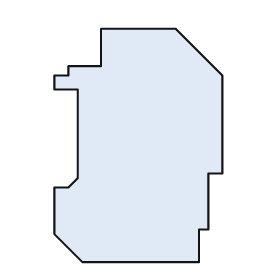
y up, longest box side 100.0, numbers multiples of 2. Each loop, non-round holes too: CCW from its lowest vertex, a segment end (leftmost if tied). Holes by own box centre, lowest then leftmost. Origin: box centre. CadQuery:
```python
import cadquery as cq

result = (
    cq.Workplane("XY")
    .moveTo(-24.0, -50.0)
    .lineTo(26.0, -50.0)
    .lineTo(26.0, -36.0)
    .lineTo(30.0, -36.0)
    .lineTo(30.0, -12.0)
    .lineTo(36.0, -12.0)
    .lineTo(36.0, 30.0)
    .lineTo(16.0, 50.0)
    .lineTo(-16.0, 50.0)
    .lineTo(-16.0, 34.0)
    .lineTo(-30.0, 34.0)
    .lineTo(-30.0, 30.0)
    .lineTo(-36.0, 30.0)
    .lineTo(-36.0, 24.0)
    .lineTo(-26.0, 24.0)
    .lineTo(-26.0, -14.0)
    .lineTo(-30.0, -18.0)
    .lineTo(-36.0, -18.0)
    .lineTo(-36.0, -38.0)
    .close()
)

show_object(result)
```